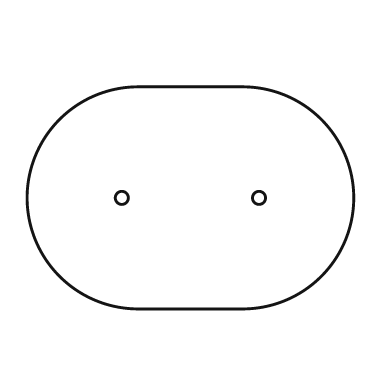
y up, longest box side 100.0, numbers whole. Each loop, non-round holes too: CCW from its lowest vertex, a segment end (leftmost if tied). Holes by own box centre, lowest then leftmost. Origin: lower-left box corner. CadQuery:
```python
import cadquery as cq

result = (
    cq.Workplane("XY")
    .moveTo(34.0, 0.0)
    .lineTo(66.0, 0.0)
    .threePointArc((100.0, 34.0), (66.0, 68.0))
    .lineTo(34.0, 68.0)
    .threePointArc((0.0, 34.0), (34.0, 0.0))
    .close()
    .moveTo(29.0, 34.0)
    .circle(2.0)
    .moveTo(71.0, 34.0)
    .circle(2.0)
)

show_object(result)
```